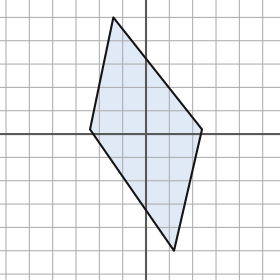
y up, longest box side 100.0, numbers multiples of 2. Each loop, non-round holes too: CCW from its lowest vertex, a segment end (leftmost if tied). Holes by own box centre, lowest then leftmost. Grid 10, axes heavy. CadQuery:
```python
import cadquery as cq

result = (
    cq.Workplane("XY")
    .moveTo(12.0, -50.0)
    .lineTo(24.0, 2.0)
    .lineTo(-14.0, 50.0)
    .lineTo(-24.0, 2.0)
    .close()
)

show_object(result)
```